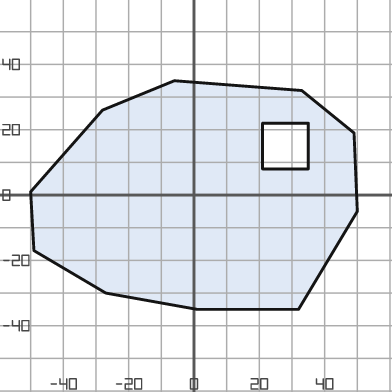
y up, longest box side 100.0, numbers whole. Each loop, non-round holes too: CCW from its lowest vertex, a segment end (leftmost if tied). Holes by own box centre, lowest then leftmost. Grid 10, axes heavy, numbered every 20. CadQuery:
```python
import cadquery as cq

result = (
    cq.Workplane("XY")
    .moveTo(1.0, -35.0)
    .lineTo(32.0, -35.0)
    .lineTo(50.0, -5.0)
    .lineTo(49.0, 19.0)
    .lineTo(33.0, 32.0)
    .lineTo(-6.0, 35.0)
    .lineTo(-28.0, 26.0)
    .lineTo(-50.0, 1.0)
    .lineTo(-49.0, -17.0)
    .lineTo(-27.0, -30.0)
    .close()
    .moveTo(21.0, 8.0)
    .lineTo(35.0, 8.0)
    .lineTo(35.0, 22.0)
    .lineTo(21.0, 22.0)
    .close()
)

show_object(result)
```